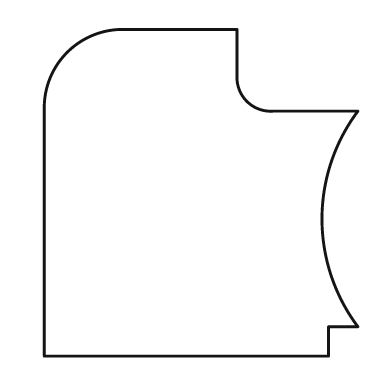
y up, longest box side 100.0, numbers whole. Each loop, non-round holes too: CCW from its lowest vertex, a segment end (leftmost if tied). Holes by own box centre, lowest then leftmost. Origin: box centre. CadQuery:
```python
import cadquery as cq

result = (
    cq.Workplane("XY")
    .moveTo(-48.0, -50.0)
    .lineTo(39.0, -50.0)
    .lineTo(39.0, -41.0)
    .lineTo(48.0, -41.0)
    .threePointArc((37.0, -8.0), (48.0, 25.0))
    .lineTo(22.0, 25.0)
    .threePointArc((14.0, 28.0), (11.0, 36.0))
    .lineTo(11.0, 50.0)
    .lineTo(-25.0, 50.0)
    .threePointArc((-41.0, 43.0), (-48.0, 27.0))
    .close()
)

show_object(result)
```